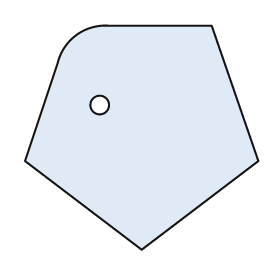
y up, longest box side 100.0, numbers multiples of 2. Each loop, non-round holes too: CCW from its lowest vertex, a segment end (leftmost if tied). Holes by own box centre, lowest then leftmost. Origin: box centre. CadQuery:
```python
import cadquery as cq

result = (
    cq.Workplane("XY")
    .moveTo(0.0, -48.0)
    .lineTo(50.0, -10.0)
    .lineTo(30.0, 48.0)
    .lineTo(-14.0, 48.0)
    .threePointArc((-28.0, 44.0), (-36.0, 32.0))
    .lineTo(-50.0, -10.0)
    .close()
    .moveTo(-18.0, 14.0)
    .circle(4.0)
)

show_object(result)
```